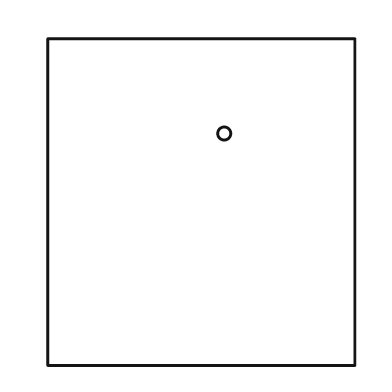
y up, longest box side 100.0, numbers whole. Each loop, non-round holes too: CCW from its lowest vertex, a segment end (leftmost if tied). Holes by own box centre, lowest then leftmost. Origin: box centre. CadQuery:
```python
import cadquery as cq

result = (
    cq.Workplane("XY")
    .moveTo(-47.0, -50.0)
    .lineTo(47.0, -50.0)
    .lineTo(47.0, 50.0)
    .lineTo(-47.0, 50.0)
    .close()
    .moveTo(7.0, 21.0)
    .circle(2.0)
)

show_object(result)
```